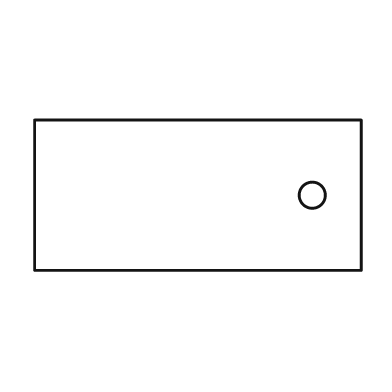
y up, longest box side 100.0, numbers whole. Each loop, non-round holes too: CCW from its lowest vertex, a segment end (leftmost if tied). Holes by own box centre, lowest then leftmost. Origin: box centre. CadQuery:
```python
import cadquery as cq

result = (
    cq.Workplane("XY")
    .moveTo(-50.0, -23.0)
    .lineTo(50.0, -23.0)
    .lineTo(50.0, 23.0)
    .lineTo(-50.0, 23.0)
    .close()
    .moveTo(35.0, 0.0)
    .circle(4.0)
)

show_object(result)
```